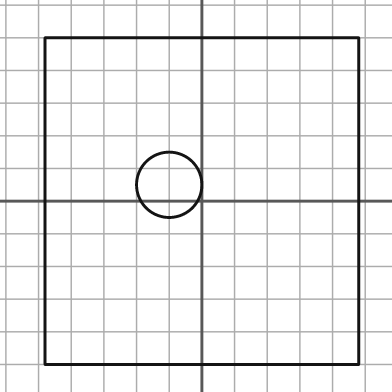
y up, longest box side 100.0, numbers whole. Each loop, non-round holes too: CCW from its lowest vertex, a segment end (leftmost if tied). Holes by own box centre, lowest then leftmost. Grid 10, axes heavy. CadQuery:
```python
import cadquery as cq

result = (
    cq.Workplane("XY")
    .moveTo(-48.0, -50.0)
    .lineTo(48.0, -50.0)
    .lineTo(48.0, 50.0)
    .lineTo(-48.0, 50.0)
    .close()
    .moveTo(-10.0, 5.0)
    .circle(10.0)
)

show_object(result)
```